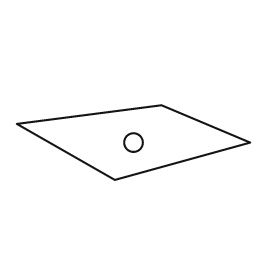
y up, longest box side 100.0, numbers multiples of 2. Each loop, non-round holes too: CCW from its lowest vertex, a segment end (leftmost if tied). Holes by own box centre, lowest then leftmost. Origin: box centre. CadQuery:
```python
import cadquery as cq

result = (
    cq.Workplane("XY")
    .moveTo(-8.0, -16.0)
    .lineTo(50.0, 0.0)
    .lineTo(12.0, 16.0)
    .lineTo(-50.0, 8.0)
    .close()
    .moveTo(0.0, 0.0)
    .circle(4.0)
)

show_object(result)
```